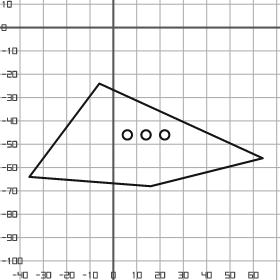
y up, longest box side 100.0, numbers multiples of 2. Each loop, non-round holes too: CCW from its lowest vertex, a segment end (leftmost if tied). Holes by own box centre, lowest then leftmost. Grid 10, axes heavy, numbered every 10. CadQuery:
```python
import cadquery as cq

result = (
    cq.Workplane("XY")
    .moveTo(16.0, -68.0)
    .lineTo(64.0, -56.0)
    .lineTo(-6.0, -24.0)
    .lineTo(-36.0, -64.0)
    .close()
    .moveTo(6.0, -46.0)
    .circle(2.0)
    .moveTo(14.0, -46.0)
    .circle(2.0)
    .moveTo(22.0, -46.0)
    .circle(2.0)
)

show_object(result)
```